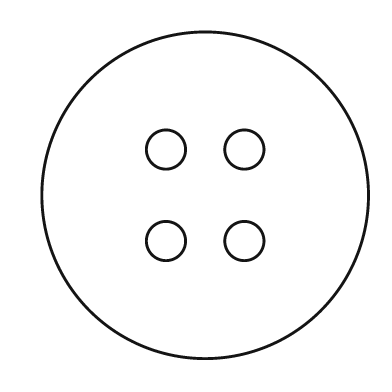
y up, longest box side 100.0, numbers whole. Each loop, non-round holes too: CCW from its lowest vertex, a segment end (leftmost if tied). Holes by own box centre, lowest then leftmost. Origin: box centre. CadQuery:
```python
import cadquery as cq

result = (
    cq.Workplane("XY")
    .moveTo(0.0, 0.0)
    .circle(50.0)
    .moveTo(-12.0, -14.0)
    .circle(6.0)
    .moveTo(12.0, -14.0)
    .circle(6.0)
    .moveTo(-12.0, 14.0)
    .circle(6.0)
    .moveTo(12.0, 14.0)
    .circle(6.0)
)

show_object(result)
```